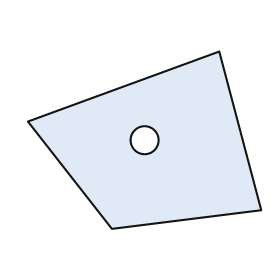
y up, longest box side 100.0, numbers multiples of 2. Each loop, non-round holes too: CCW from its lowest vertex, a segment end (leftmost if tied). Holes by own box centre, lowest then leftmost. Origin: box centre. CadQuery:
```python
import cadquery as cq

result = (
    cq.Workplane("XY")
    .moveTo(-14.0, -38.0)
    .lineTo(50.0, -30.0)
    .lineTo(32.0, 38.0)
    .lineTo(-50.0, 8.0)
    .close()
    .moveTo(0.0, 0.0)
    .circle(6.0)
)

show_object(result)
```